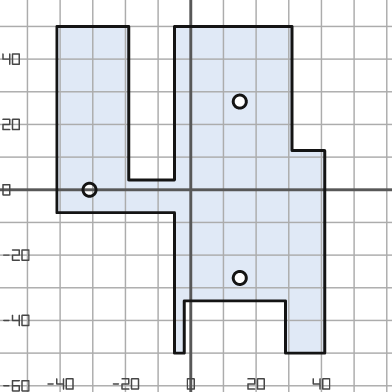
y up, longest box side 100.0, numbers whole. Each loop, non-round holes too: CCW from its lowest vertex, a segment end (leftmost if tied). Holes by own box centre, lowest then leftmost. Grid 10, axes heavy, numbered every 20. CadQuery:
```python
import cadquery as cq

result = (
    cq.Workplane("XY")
    .moveTo(-5.0, -50.0)
    .lineTo(-2.0, -50.0)
    .lineTo(-2.0, -34.0)
    .lineTo(29.0, -34.0)
    .lineTo(29.0, -50.0)
    .lineTo(41.0, -50.0)
    .lineTo(41.0, 12.0)
    .lineTo(31.0, 12.0)
    .lineTo(31.0, 50.0)
    .lineTo(-5.0, 50.0)
    .lineTo(-5.0, 3.0)
    .lineTo(-19.0, 3.0)
    .lineTo(-19.0, 50.0)
    .lineTo(-41.0, 50.0)
    .lineTo(-41.0, -7.0)
    .lineTo(-5.0, -7.0)
    .close()
    .moveTo(15.0, -27.0)
    .circle(2.0)
    .moveTo(-31.0, 0.0)
    .circle(2.0)
    .moveTo(15.0, 27.0)
    .circle(2.0)
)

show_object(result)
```